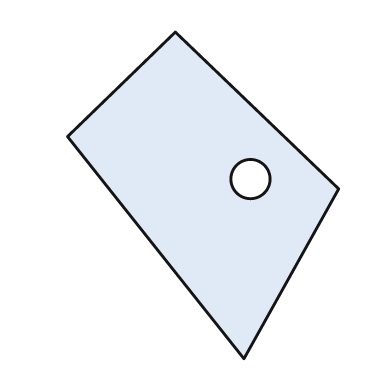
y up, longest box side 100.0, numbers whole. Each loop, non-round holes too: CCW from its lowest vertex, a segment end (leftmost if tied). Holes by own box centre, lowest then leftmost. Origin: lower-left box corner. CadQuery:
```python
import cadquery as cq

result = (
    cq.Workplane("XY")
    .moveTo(54.0, 0.0)
    .lineTo(83.0, 52.0)
    .lineTo(33.0, 100.0)
    .lineTo(0.0, 68.0)
    .close()
    .moveTo(56.0, 55.0)
    .circle(6.0)
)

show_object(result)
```